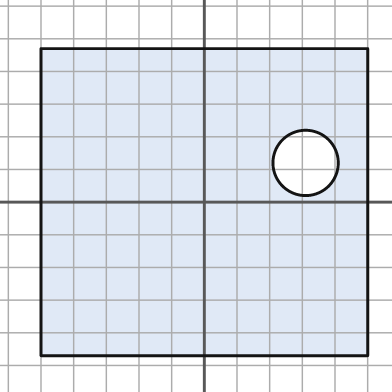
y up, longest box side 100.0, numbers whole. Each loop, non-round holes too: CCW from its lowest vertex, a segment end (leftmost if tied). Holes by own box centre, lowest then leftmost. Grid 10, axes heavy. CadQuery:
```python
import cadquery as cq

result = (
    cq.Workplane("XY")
    .moveTo(-50.0, -47.0)
    .lineTo(50.0, -47.0)
    .lineTo(50.0, 47.0)
    .lineTo(-50.0, 47.0)
    .close()
    .moveTo(31.0, 12.0)
    .circle(10.0)
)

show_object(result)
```